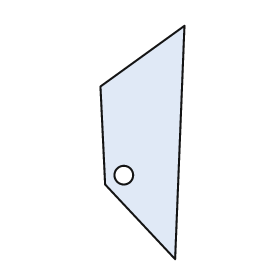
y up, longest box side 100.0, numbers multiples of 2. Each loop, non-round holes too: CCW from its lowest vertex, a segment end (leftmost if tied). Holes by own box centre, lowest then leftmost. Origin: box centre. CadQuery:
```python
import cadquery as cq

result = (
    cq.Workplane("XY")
    .moveTo(14.0, -50.0)
    .lineTo(18.0, 50.0)
    .lineTo(-18.0, 24.0)
    .lineTo(-16.0, -18.0)
    .close()
    .moveTo(-8.0, -14.0)
    .circle(4.0)
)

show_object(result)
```